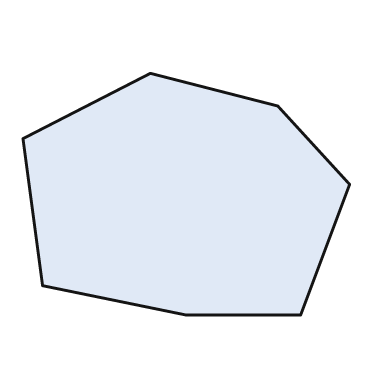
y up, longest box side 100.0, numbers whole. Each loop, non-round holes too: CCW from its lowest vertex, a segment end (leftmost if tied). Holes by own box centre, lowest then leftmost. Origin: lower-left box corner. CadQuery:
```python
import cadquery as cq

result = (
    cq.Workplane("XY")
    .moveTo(50.0, 0.0)
    .lineTo(85.0, 0.0)
    .lineTo(100.0, 40.0)
    .lineTo(78.0, 64.0)
    .lineTo(39.0, 74.0)
    .lineTo(0.0, 54.0)
    .lineTo(6.0, 9.0)
    .close()
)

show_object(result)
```